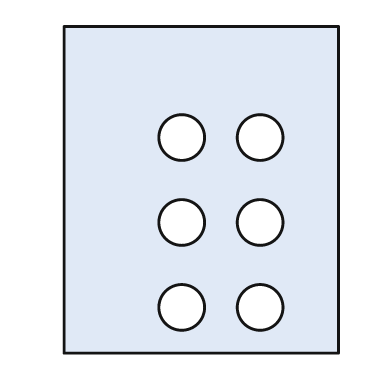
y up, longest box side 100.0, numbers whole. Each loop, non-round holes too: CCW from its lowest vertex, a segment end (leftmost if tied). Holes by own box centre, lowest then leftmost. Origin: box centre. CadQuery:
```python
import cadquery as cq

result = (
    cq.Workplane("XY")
    .moveTo(-42.0, -50.0)
    .lineTo(42.0, -50.0)
    .lineTo(42.0, 50.0)
    .lineTo(-42.0, 50.0)
    .close()
    .moveTo(-6.0, -36.0)
    .circle(7.0)
    .moveTo(18.0, -36.0)
    .circle(7.0)
    .moveTo(-6.0, -10.0)
    .circle(7.0)
    .moveTo(18.0, -10.0)
    .circle(7.0)
    .moveTo(-6.0, 16.0)
    .circle(7.0)
    .moveTo(18.0, 16.0)
    .circle(7.0)
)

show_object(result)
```